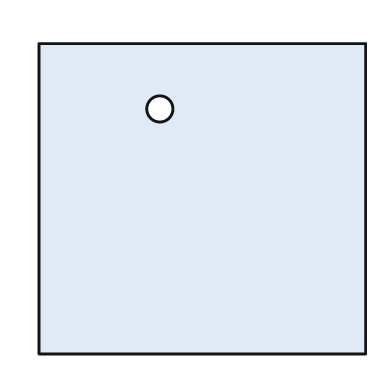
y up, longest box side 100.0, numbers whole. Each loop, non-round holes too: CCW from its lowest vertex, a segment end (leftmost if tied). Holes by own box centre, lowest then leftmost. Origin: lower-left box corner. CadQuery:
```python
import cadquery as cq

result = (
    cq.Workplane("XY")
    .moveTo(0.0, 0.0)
    .lineTo(100.0, 0.0)
    .lineTo(100.0, 95.0)
    .lineTo(0.0, 95.0)
    .close()
    .moveTo(37.0, 75.0)
    .circle(4.0)
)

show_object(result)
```